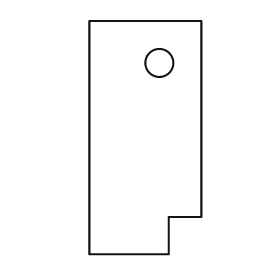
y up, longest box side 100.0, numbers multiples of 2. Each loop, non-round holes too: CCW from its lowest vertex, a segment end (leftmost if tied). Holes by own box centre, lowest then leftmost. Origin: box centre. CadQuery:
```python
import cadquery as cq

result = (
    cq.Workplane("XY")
    .moveTo(-24.0, -50.0)
    .lineTo(10.0, -50.0)
    .lineTo(10.0, -34.0)
    .lineTo(24.0, -34.0)
    .lineTo(24.0, 50.0)
    .lineTo(-24.0, 50.0)
    .close()
    .moveTo(6.0, 32.0)
    .circle(6.0)
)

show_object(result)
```